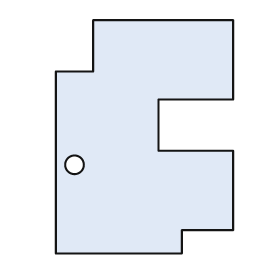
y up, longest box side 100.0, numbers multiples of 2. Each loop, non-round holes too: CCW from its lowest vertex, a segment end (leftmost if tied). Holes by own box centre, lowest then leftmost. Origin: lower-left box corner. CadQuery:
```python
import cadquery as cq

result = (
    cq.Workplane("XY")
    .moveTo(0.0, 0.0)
    .lineTo(54.0, 0.0)
    .lineTo(54.0, 10.0)
    .lineTo(76.0, 10.0)
    .lineTo(76.0, 44.0)
    .lineTo(44.0, 44.0)
    .lineTo(44.0, 66.0)
    .lineTo(76.0, 66.0)
    .lineTo(76.0, 100.0)
    .lineTo(16.0, 100.0)
    .lineTo(16.0, 78.0)
    .lineTo(0.0, 78.0)
    .close()
    .moveTo(8.0, 38.0)
    .circle(4.0)
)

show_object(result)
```